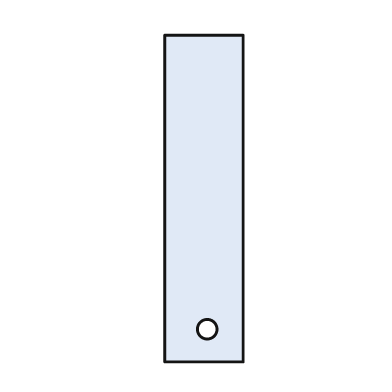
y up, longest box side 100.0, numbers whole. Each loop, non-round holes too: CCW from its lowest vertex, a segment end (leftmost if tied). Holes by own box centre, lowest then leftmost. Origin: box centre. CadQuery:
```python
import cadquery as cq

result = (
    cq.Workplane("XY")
    .moveTo(-12.0, -50.0)
    .lineTo(12.0, -50.0)
    .lineTo(12.0, 50.0)
    .lineTo(-12.0, 50.0)
    .close()
    .moveTo(1.0, -40.0)
    .circle(3.0)
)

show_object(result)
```